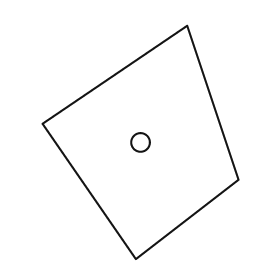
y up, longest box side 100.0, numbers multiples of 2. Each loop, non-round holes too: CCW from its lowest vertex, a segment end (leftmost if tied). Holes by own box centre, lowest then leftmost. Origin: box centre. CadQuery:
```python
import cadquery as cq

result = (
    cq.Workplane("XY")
    .moveTo(-2.0, -50.0)
    .lineTo(42.0, -16.0)
    .lineTo(20.0, 50.0)
    .lineTo(-42.0, 8.0)
    .close()
    .moveTo(0.0, 0.0)
    .circle(4.0)
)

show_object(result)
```